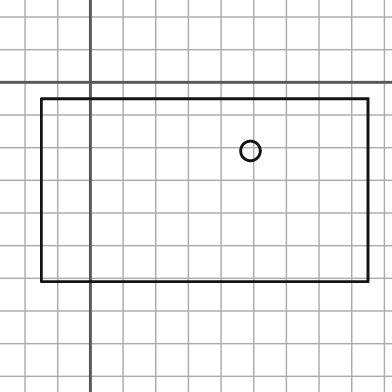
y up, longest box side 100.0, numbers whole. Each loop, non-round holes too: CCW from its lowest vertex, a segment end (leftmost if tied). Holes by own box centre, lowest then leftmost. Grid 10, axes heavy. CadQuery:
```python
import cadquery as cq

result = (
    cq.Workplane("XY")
    .moveTo(-15.0, -61.0)
    .lineTo(85.0, -61.0)
    .lineTo(85.0, -5.0)
    .lineTo(-15.0, -5.0)
    .close()
    .moveTo(49.0, -21.0)
    .circle(3.0)
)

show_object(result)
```